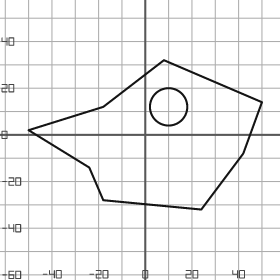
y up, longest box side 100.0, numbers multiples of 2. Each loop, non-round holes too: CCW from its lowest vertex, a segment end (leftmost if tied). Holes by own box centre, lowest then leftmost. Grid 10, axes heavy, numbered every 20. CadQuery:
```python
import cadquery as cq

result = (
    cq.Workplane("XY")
    .moveTo(24.0, -32.0)
    .lineTo(42.0, -8.0)
    .lineTo(50.0, 14.0)
    .lineTo(8.0, 32.0)
    .lineTo(-18.0, 12.0)
    .lineTo(-50.0, 2.0)
    .lineTo(-24.0, -14.0)
    .lineTo(-18.0, -28.0)
    .close()
    .moveTo(10.0, 12.0)
    .circle(8.0)
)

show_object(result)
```